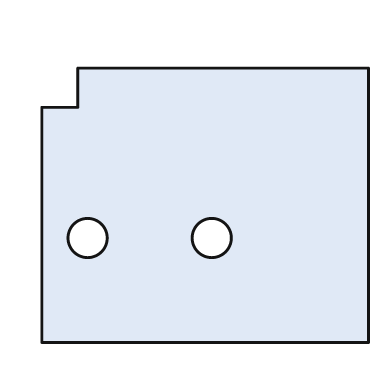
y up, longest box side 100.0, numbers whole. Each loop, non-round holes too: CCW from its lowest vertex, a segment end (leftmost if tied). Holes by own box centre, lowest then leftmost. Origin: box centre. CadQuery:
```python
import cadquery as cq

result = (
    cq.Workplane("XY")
    .moveTo(-50.0, -42.0)
    .lineTo(50.0, -42.0)
    .lineTo(50.0, 42.0)
    .lineTo(-39.0, 42.0)
    .lineTo(-39.0, 30.0)
    .lineTo(-50.0, 30.0)
    .close()
    .moveTo(-36.0, -10.0)
    .circle(6.0)
    .moveTo(2.0, -10.0)
    .circle(6.0)
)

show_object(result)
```